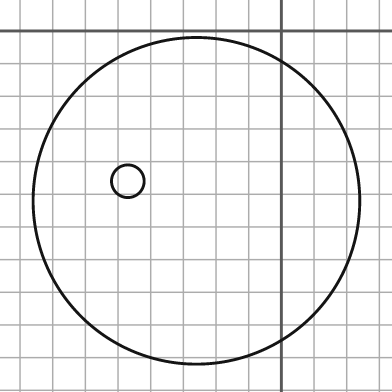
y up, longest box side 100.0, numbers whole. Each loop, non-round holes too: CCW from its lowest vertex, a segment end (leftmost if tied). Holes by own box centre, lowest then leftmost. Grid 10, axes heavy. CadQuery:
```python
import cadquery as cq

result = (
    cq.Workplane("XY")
    .moveTo(-26.0, -52.0)
    .circle(50.0)
    .moveTo(-47.0, -46.0)
    .circle(5.0)
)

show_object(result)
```